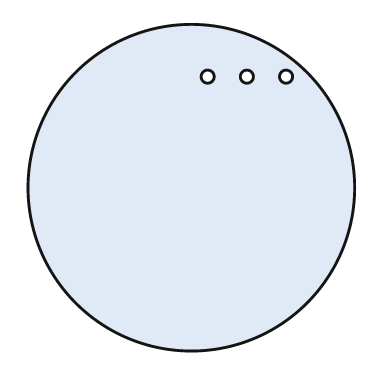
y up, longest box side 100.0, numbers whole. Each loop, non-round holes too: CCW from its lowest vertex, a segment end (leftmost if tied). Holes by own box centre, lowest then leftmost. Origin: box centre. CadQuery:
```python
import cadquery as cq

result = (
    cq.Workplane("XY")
    .moveTo(0.0, 0.0)
    .circle(50.0)
    .moveTo(5.0, 34.0)
    .circle(2.0)
    .moveTo(17.0, 34.0)
    .circle(2.0)
    .moveTo(29.0, 34.0)
    .circle(2.0)
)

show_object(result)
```